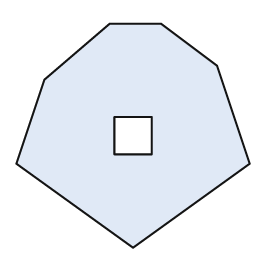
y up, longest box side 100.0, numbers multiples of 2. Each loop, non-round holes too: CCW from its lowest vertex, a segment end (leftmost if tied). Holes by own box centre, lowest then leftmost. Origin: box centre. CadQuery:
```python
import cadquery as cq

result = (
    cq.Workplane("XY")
    .moveTo(0.0, -48.0)
    .lineTo(50.0, -12.0)
    .lineTo(36.0, 30.0)
    .lineTo(12.0, 48.0)
    .lineTo(-10.0, 48.0)
    .lineTo(-38.0, 24.0)
    .lineTo(-50.0, -12.0)
    .close()
    .moveTo(-8.0, -8.0)
    .lineTo(8.0, -8.0)
    .lineTo(8.0, 8.0)
    .lineTo(-8.0, 8.0)
    .close()
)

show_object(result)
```